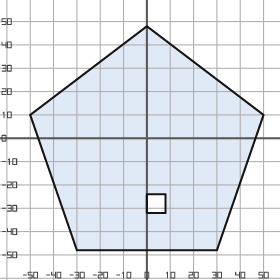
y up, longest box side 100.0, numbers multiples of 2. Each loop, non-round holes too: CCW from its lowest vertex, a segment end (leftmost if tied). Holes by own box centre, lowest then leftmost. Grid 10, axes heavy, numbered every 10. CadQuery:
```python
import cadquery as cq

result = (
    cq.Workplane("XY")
    .moveTo(-30.0, -48.0)
    .lineTo(30.0, -48.0)
    .lineTo(50.0, 10.0)
    .lineTo(0.0, 48.0)
    .lineTo(-50.0, 10.0)
    .close()
    .moveTo(0.0, -32.0)
    .lineTo(8.0, -32.0)
    .lineTo(8.0, -24.0)
    .lineTo(0.0, -24.0)
    .close()
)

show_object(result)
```